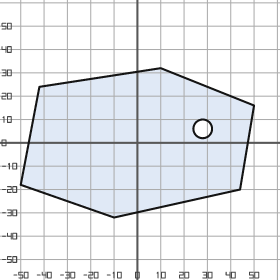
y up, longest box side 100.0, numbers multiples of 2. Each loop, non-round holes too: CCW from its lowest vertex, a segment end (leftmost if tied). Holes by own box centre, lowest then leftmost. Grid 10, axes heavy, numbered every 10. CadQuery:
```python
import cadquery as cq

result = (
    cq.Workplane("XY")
    .moveTo(-10.0, -32.0)
    .lineTo(44.0, -20.0)
    .lineTo(50.0, 16.0)
    .lineTo(10.0, 32.0)
    .lineTo(-42.0, 24.0)
    .lineTo(-50.0, -18.0)
    .close()
    .moveTo(28.0, 6.0)
    .circle(4.0)
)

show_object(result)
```